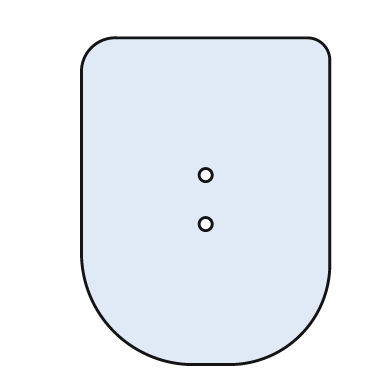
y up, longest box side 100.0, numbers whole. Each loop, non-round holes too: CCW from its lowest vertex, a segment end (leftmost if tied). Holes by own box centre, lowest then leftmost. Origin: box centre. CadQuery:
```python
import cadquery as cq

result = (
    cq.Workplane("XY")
    .moveTo(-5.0, -50.0)
    .lineTo(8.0, -50.0)
    .threePointArc((29.0, -41.0), (38.0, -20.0))
    .lineTo(38.0, 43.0)
    .threePointArc((36.0, 48.0), (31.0, 50.0))
    .lineTo(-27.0, 50.0)
    .threePointArc((-35.0, 47.0), (-38.0, 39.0))
    .lineTo(-38.0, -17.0)
    .threePointArc((-28.0, -40.0), (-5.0, -50.0))
    .close()
    .moveTo(0.0, -7.0)
    .circle(2.0)
    .moveTo(0.0, 8.0)
    .circle(2.0)
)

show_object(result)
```